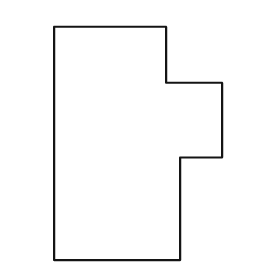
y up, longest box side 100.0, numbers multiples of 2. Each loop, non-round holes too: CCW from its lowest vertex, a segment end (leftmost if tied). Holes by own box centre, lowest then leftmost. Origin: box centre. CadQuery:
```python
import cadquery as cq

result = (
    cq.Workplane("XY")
    .moveTo(-36.0, -50.0)
    .lineTo(18.0, -50.0)
    .lineTo(18.0, -6.0)
    .lineTo(36.0, -6.0)
    .lineTo(36.0, 26.0)
    .lineTo(12.0, 26.0)
    .lineTo(12.0, 50.0)
    .lineTo(-36.0, 50.0)
    .close()
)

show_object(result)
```